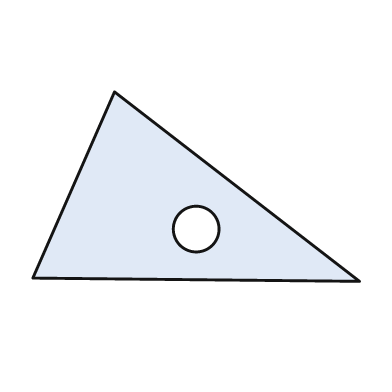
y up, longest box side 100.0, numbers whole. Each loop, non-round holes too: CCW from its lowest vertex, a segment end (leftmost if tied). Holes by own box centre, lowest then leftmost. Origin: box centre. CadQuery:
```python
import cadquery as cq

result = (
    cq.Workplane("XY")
    .moveTo(50.0, -29.0)
    .lineTo(-25.0, 29.0)
    .lineTo(-50.0, -28.0)
    .close()
    .moveTo(0.0, -13.0)
    .circle(7.0)
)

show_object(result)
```